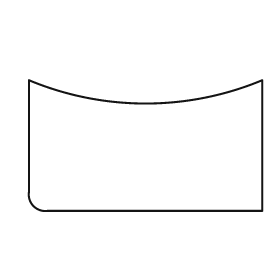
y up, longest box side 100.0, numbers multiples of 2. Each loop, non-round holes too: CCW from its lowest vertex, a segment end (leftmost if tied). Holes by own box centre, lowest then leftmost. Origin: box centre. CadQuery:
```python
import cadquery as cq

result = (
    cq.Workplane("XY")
    .moveTo(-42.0, -28.0)
    .lineTo(50.0, -28.0)
    .lineTo(50.0, 28.0)
    .threePointArc((0.0, 18.0), (-50.0, 28.0))
    .lineTo(-50.0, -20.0)
    .threePointArc((-48.0, -26.0), (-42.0, -28.0))
    .close()
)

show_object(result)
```